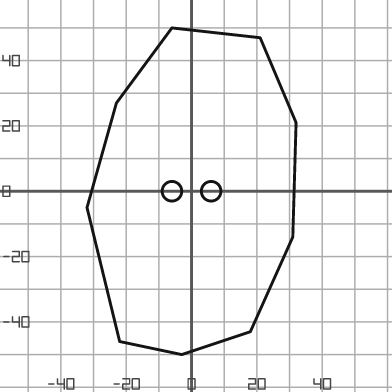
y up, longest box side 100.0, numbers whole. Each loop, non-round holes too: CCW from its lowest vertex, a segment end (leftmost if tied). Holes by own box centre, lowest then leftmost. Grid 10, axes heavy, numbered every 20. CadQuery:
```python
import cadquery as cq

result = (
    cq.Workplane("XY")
    .moveTo(-3.0, -50.0)
    .lineTo(18.0, -43.0)
    .lineTo(31.0, -14.0)
    .lineTo(32.0, 21.0)
    .lineTo(21.0, 47.0)
    .lineTo(-6.0, 50.0)
    .lineTo(-23.0, 27.0)
    .lineTo(-32.0, -5.0)
    .lineTo(-22.0, -46.0)
    .close()
    .moveTo(-6.0, 0.0)
    .circle(3.0)
    .moveTo(6.0, 0.0)
    .circle(3.0)
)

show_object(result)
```